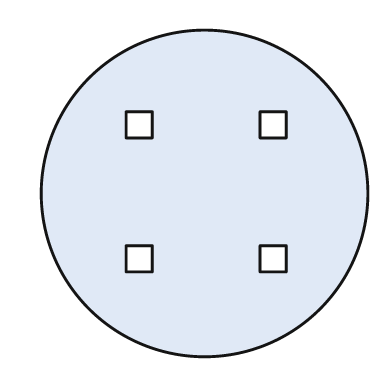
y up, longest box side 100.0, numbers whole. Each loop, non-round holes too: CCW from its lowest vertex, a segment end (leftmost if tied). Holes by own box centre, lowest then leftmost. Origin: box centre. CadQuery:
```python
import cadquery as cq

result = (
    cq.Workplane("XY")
    .moveTo(0.0, 0.0)
    .circle(50.0)
    .moveTo(-24.0, -24.0)
    .lineTo(-16.0, -24.0)
    .lineTo(-16.0, -16.0)
    .lineTo(-24.0, -16.0)
    .close()
    .moveTo(17.0, -24.0)
    .lineTo(25.0, -24.0)
    .lineTo(25.0, -16.0)
    .lineTo(17.0, -16.0)
    .close()
    .moveTo(-24.0, 17.0)
    .lineTo(-16.0, 17.0)
    .lineTo(-16.0, 25.0)
    .lineTo(-24.0, 25.0)
    .close()
    .moveTo(17.0, 17.0)
    .lineTo(25.0, 17.0)
    .lineTo(25.0, 25.0)
    .lineTo(17.0, 25.0)
    .close()
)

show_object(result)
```